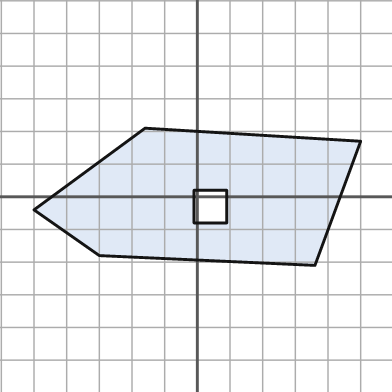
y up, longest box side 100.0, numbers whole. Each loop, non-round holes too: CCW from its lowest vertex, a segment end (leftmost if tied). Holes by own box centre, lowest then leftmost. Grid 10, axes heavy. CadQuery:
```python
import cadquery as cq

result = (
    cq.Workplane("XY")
    .moveTo(36.0, -21.0)
    .lineTo(50.0, 17.0)
    .lineTo(-16.0, 21.0)
    .lineTo(-50.0, -4.0)
    .lineTo(-30.0, -18.0)
    .close()
    .moveTo(-1.0, -8.0)
    .lineTo(9.0, -8.0)
    .lineTo(9.0, 2.0)
    .lineTo(-1.0, 2.0)
    .close()
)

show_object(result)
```